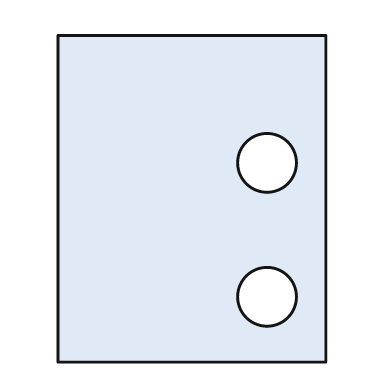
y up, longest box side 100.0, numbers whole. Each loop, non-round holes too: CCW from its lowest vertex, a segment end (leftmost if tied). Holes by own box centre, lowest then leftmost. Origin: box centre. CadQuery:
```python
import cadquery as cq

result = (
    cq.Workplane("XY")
    .moveTo(-41.0, -50.0)
    .lineTo(41.0, -50.0)
    .lineTo(41.0, 50.0)
    .lineTo(-41.0, 50.0)
    .close()
    .moveTo(23.0, -30.0)
    .circle(9.0)
    .moveTo(23.0, 11.0)
    .circle(9.0)
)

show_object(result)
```